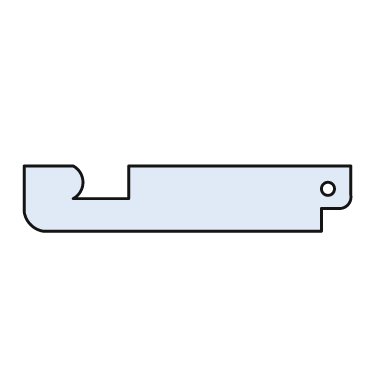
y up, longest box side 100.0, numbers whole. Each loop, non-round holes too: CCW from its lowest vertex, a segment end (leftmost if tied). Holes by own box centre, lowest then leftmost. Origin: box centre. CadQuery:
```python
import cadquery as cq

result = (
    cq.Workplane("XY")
    .moveTo(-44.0, -10.0)
    .lineTo(41.0, -10.0)
    .lineTo(41.0, -3.0)
    .lineTo(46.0, -3.0)
    .threePointArc((49.0, -2.0), (50.0, 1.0))
    .lineTo(50.0, 10.0)
    .lineTo(-18.0, 10.0)
    .lineTo(-18.0, 0.0)
    .lineTo(-35.0, 0.0)
    .threePointArc((-32.0, 5.0), (-35.0, 10.0))
    .lineTo(-50.0, 10.0)
    .lineTo(-50.0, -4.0)
    .threePointArc((-48.0, -8.0), (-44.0, -10.0))
    .close()
    .moveTo(43.0, 3.0)
    .circle(2.0)
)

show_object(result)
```